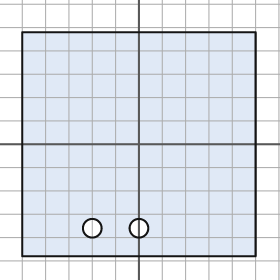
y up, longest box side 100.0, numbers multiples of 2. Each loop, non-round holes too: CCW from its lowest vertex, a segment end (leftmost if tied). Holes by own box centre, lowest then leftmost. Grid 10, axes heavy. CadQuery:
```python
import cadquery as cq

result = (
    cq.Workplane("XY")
    .moveTo(-50.0, -48.0)
    .lineTo(50.0, -48.0)
    .lineTo(50.0, 48.0)
    .lineTo(-50.0, 48.0)
    .close()
    .moveTo(-20.0, -36.0)
    .circle(4.0)
    .moveTo(0.0, -36.0)
    .circle(4.0)
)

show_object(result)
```